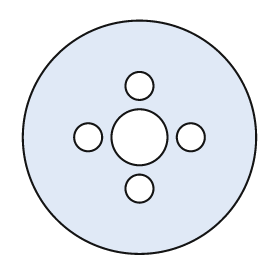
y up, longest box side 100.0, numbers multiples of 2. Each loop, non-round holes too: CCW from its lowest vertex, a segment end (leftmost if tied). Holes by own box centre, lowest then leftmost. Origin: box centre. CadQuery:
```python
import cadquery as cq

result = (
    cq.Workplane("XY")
    .moveTo(0.0, 0.0)
    .circle(50.0)
    .moveTo(0.0, -22.0)
    .circle(6.0)
    .moveTo(-22.0, 0.0)
    .circle(6.0)
    .moveTo(0.0, 0.0)
    .circle(12.0)
    .moveTo(22.0, 0.0)
    .circle(6.0)
    .moveTo(0.0, 22.0)
    .circle(6.0)
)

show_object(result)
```